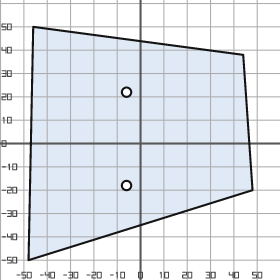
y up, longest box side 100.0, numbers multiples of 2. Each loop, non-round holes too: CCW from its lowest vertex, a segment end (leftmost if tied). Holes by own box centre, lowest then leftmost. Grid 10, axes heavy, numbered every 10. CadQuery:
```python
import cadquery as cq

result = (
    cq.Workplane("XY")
    .moveTo(-48.0, -50.0)
    .lineTo(48.0, -20.0)
    .lineTo(44.0, 38.0)
    .lineTo(-46.0, 50.0)
    .close()
    .moveTo(-6.0, -18.0)
    .circle(2.0)
    .moveTo(-6.0, 22.0)
    .circle(2.0)
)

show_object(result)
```